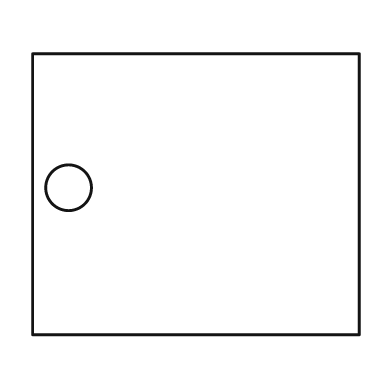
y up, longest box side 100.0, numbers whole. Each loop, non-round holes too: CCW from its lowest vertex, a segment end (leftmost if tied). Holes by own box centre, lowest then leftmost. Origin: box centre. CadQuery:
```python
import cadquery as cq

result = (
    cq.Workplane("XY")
    .moveTo(-50.0, -43.0)
    .lineTo(50.0, -43.0)
    .lineTo(50.0, 43.0)
    .lineTo(-50.0, 43.0)
    .close()
    .moveTo(-39.0, 2.0)
    .circle(7.0)
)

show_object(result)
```